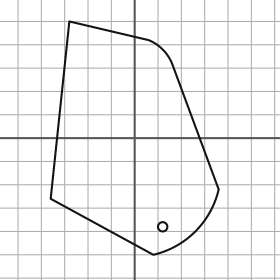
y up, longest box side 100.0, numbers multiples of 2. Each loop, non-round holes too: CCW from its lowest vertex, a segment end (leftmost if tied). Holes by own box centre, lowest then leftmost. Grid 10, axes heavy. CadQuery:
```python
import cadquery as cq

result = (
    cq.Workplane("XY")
    .moveTo(8.0, -50.0)
    .threePointArc((26.0, -40.0), (36.0, -22.0))
    .lineTo(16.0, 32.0)
    .threePointArc((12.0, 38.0), (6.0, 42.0))
    .lineTo(-28.0, 50.0)
    .lineTo(-36.0, -26.0)
    .close()
    .moveTo(12.0, -38.0)
    .circle(2.0)
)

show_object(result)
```